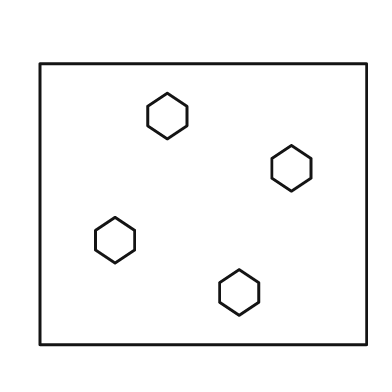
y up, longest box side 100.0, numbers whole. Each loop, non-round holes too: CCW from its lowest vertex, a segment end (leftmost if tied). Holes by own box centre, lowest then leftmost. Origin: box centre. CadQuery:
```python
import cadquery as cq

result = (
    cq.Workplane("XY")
    .moveTo(-50.0, -43.0)
    .lineTo(50.0, -43.0)
    .lineTo(50.0, 43.0)
    .lineTo(-50.0, 43.0)
    .close()
    .moveTo(11.0, -34.0)
    .lineTo(17.0, -30.0)
    .lineTo(17.0, -24.0)
    .lineTo(11.0, -20.0)
    .lineTo(5.0, -24.0)
    .lineTo(5.0, -30.0)
    .close()
    .moveTo(-27.0, -18.0)
    .lineTo(-21.0, -14.0)
    .lineTo(-21.0, -8.0)
    .lineTo(-27.0, -4.0)
    .lineTo(-33.0, -8.0)
    .lineTo(-33.0, -14.0)
    .close()
    .moveTo(27.0, 4.0)
    .lineTo(33.0, 8.0)
    .lineTo(33.0, 14.0)
    .lineTo(27.0, 18.0)
    .lineTo(21.0, 14.0)
    .lineTo(21.0, 8.0)
    .close()
    .moveTo(-11.0, 20.0)
    .lineTo(-5.0, 24.0)
    .lineTo(-5.0, 30.0)
    .lineTo(-11.0, 34.0)
    .lineTo(-17.0, 30.0)
    .lineTo(-17.0, 24.0)
    .close()
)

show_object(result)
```